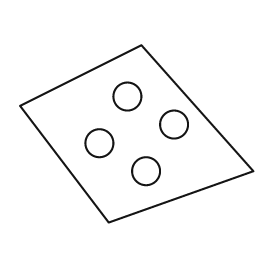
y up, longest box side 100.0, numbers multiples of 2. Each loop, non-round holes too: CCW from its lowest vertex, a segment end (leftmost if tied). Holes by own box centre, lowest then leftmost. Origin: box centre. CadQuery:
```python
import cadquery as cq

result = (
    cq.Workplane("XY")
    .moveTo(-12.0, -38.0)
    .lineTo(50.0, -16.0)
    .lineTo(2.0, 38.0)
    .lineTo(-50.0, 12.0)
    .close()
    .moveTo(4.0, -16.0)
    .circle(6.0)
    .moveTo(-16.0, -4.0)
    .circle(6.0)
    .moveTo(16.0, 4.0)
    .circle(6.0)
    .moveTo(-4.0, 16.0)
    .circle(6.0)
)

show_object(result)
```